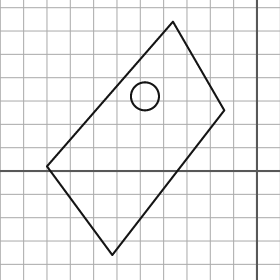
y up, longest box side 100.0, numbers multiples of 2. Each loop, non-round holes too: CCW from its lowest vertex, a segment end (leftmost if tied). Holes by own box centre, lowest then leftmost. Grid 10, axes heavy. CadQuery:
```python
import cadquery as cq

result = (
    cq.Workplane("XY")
    .moveTo(-62.0, -36.0)
    .lineTo(-14.0, 26.0)
    .lineTo(-36.0, 64.0)
    .lineTo(-90.0, 2.0)
    .close()
    .moveTo(-48.0, 32.0)
    .circle(6.0)
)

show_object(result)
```